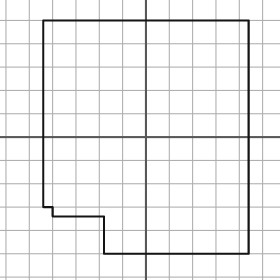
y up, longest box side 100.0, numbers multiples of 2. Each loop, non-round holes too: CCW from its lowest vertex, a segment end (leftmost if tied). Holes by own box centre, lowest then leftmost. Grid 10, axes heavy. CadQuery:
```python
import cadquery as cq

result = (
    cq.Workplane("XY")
    .moveTo(-18.0, -50.0)
    .lineTo(44.0, -50.0)
    .lineTo(44.0, 50.0)
    .lineTo(-44.0, 50.0)
    .lineTo(-44.0, -30.0)
    .lineTo(-40.0, -30.0)
    .lineTo(-40.0, -34.0)
    .lineTo(-18.0, -34.0)
    .close()
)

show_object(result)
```